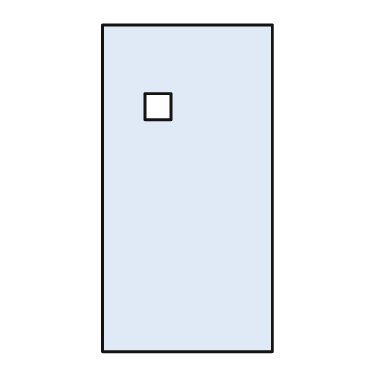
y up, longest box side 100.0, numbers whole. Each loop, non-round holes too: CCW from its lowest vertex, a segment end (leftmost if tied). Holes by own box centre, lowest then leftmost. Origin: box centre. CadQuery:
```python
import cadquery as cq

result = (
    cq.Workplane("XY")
    .moveTo(-26.0, -50.0)
    .lineTo(26.0, -50.0)
    .lineTo(26.0, 50.0)
    .lineTo(-26.0, 50.0)
    .close()
    .moveTo(-13.0, 21.0)
    .lineTo(-5.0, 21.0)
    .lineTo(-5.0, 29.0)
    .lineTo(-13.0, 29.0)
    .close()
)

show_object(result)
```